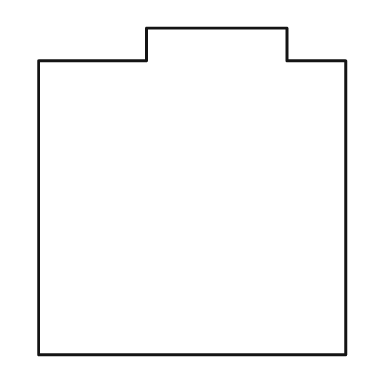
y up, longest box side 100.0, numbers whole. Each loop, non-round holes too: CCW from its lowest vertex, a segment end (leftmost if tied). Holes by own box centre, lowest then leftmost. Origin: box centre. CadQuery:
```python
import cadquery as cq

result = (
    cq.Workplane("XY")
    .moveTo(-47.0, -50.0)
    .lineTo(47.0, -50.0)
    .lineTo(47.0, 40.0)
    .lineTo(29.0, 40.0)
    .lineTo(29.0, 50.0)
    .lineTo(-14.0, 50.0)
    .lineTo(-14.0, 40.0)
    .lineTo(-47.0, 40.0)
    .close()
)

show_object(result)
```